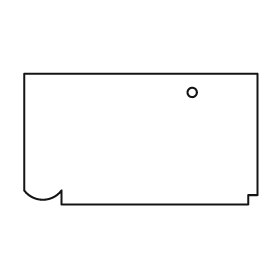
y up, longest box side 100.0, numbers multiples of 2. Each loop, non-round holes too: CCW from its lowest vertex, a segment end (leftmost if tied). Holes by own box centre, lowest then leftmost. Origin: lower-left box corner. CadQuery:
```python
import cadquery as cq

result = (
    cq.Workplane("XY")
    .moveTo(16.0, 0.0)
    .lineTo(96.0, 0.0)
    .lineTo(96.0, 4.0)
    .lineTo(100.0, 4.0)
    .lineTo(100.0, 56.0)
    .lineTo(0.0, 56.0)
    .lineTo(0.0, 6.0)
    .threePointArc((8.0, 2.0), (16.0, 6.0))
    .close()
    .moveTo(72.0, 48.0)
    .circle(2.0)
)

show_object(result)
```